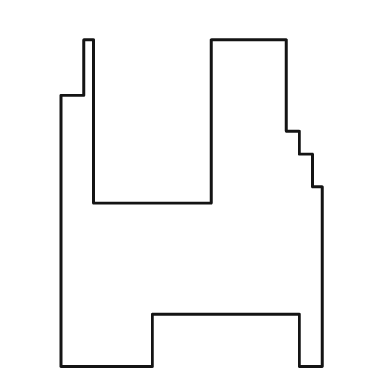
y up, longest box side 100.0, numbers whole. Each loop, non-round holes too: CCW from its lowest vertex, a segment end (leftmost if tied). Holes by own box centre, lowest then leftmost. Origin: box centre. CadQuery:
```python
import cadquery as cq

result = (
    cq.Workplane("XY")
    .moveTo(-40.0, -50.0)
    .lineTo(-12.0, -50.0)
    .lineTo(-12.0, -34.0)
    .lineTo(33.0, -34.0)
    .lineTo(33.0, -50.0)
    .lineTo(40.0, -50.0)
    .lineTo(40.0, 5.0)
    .lineTo(37.0, 5.0)
    .lineTo(37.0, 15.0)
    .lineTo(33.0, 15.0)
    .lineTo(33.0, 22.0)
    .lineTo(29.0, 22.0)
    .lineTo(29.0, 50.0)
    .lineTo(6.0, 50.0)
    .lineTo(6.0, 0.0)
    .lineTo(-30.0, 0.0)
    .lineTo(-30.0, 50.0)
    .lineTo(-33.0, 50.0)
    .lineTo(-33.0, 33.0)
    .lineTo(-40.0, 33.0)
    .close()
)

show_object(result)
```